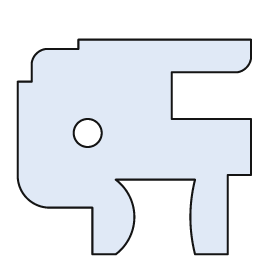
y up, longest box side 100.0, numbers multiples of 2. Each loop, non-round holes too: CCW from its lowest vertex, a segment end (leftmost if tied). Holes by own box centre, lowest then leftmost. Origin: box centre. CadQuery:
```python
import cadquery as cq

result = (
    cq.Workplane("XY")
    .moveTo(-18.0, -46.0)
    .lineTo(-8.0, -46.0)
    .threePointArc((0.0, -30.0), (-8.0, -14.0))
    .lineTo(26.0, -14.0)
    .threePointArc((24.0, -30.0), (26.0, -46.0))
    .lineTo(40.0, -46.0)
    .lineTo(40.0, -12.0)
    .lineTo(50.0, -12.0)
    .lineTo(50.0, 12.0)
    .lineTo(16.0, 12.0)
    .lineTo(16.0, 32.0)
    .lineTo(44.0, 32.0)
    .threePointArc((48.0, 34.0), (50.0, 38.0))
    .lineTo(50.0, 46.0)
    .lineTo(-24.0, 46.0)
    .lineTo(-24.0, 42.0)
    .lineTo(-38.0, 42.0)
    .threePointArc((-42.0, 40.0), (-44.0, 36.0))
    .lineTo(-44.0, 28.0)
    .lineTo(-50.0, 28.0)
    .lineTo(-50.0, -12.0)
    .threePointArc((-46.0, -22.0), (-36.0, -26.0))
    .lineTo(-18.0, -26.0)
    .close()
    .moveTo(-20.0, 6.0)
    .circle(6.0)
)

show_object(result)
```